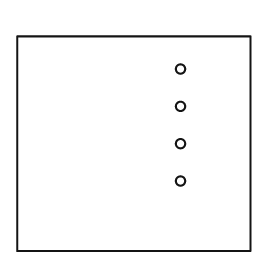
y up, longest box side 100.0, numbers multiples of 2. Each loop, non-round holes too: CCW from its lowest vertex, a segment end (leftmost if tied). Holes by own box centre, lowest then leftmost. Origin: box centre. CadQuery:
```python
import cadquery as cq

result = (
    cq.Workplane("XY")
    .moveTo(-50.0, -46.0)
    .lineTo(50.0, -46.0)
    .lineTo(50.0, 46.0)
    .lineTo(-50.0, 46.0)
    .close()
    .moveTo(20.0, -16.0)
    .circle(2.0)
    .moveTo(20.0, 0.0)
    .circle(2.0)
    .moveTo(20.0, 16.0)
    .circle(2.0)
    .moveTo(20.0, 32.0)
    .circle(2.0)
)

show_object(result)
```